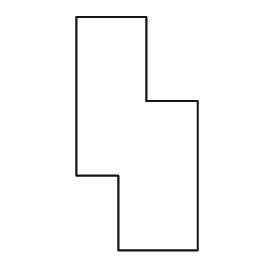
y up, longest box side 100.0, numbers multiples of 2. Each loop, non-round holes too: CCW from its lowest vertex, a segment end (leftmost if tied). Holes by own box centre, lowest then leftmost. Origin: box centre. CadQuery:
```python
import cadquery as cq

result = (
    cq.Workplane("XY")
    .moveTo(-8.0, -50.0)
    .lineTo(26.0, -50.0)
    .lineTo(26.0, 14.0)
    .lineTo(4.0, 14.0)
    .lineTo(4.0, 50.0)
    .lineTo(-26.0, 50.0)
    .lineTo(-26.0, -18.0)
    .lineTo(-8.0, -18.0)
    .close()
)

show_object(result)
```